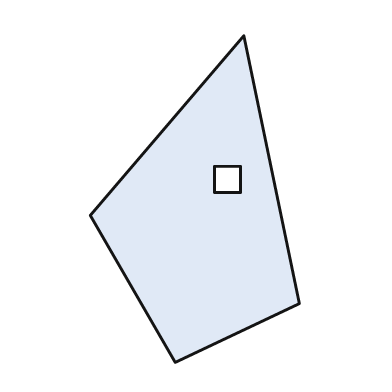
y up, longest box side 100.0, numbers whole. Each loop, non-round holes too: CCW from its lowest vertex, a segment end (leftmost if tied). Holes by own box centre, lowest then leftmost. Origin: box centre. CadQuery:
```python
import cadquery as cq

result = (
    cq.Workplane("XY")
    .moveTo(-6.0, -50.0)
    .lineTo(32.0, -32.0)
    .lineTo(15.0, 50.0)
    .lineTo(-32.0, -5.0)
    .close()
    .moveTo(6.0, 2.0)
    .lineTo(14.0, 2.0)
    .lineTo(14.0, 10.0)
    .lineTo(6.0, 10.0)
    .close()
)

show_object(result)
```